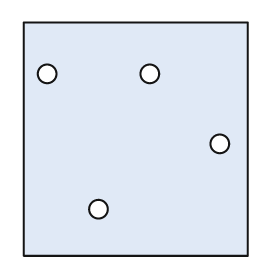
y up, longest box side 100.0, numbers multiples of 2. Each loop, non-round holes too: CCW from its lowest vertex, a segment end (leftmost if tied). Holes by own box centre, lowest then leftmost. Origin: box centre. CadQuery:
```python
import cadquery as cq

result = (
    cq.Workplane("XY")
    .moveTo(-48.0, -50.0)
    .lineTo(48.0, -50.0)
    .lineTo(48.0, 50.0)
    .lineTo(-48.0, 50.0)
    .close()
    .moveTo(-16.0, -30.0)
    .circle(4.0)
    .moveTo(36.0, -2.0)
    .circle(4.0)
    .moveTo(-38.0, 28.0)
    .circle(4.0)
    .moveTo(6.0, 28.0)
    .circle(4.0)
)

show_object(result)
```